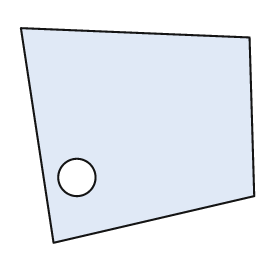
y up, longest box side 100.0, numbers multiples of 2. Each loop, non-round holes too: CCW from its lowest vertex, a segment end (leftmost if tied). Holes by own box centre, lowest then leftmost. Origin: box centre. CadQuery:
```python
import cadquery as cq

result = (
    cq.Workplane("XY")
    .moveTo(-36.0, -46.0)
    .lineTo(50.0, -26.0)
    .lineTo(48.0, 42.0)
    .lineTo(-50.0, 46.0)
    .close()
    .moveTo(-26.0, -18.0)
    .circle(8.0)
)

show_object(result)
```